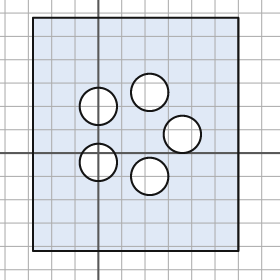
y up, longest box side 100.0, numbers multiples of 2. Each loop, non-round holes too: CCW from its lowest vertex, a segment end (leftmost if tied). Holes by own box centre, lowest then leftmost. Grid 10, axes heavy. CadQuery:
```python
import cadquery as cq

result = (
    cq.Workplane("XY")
    .moveTo(-28.0, -42.0)
    .lineTo(60.0, -42.0)
    .lineTo(60.0, 58.0)
    .lineTo(-28.0, 58.0)
    .close()
    .moveTo(22.0, -10.0)
    .circle(8.0)
    .moveTo(0.0, -4.0)
    .circle(8.0)
    .moveTo(36.0, 8.0)
    .circle(8.0)
    .moveTo(0.0, 20.0)
    .circle(8.0)
    .moveTo(22.0, 26.0)
    .circle(8.0)
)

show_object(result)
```